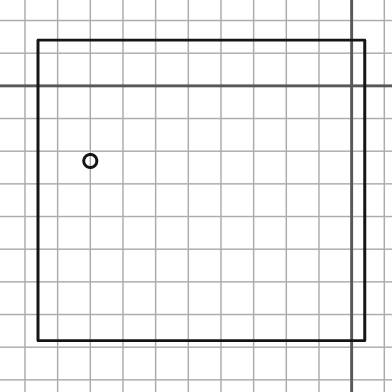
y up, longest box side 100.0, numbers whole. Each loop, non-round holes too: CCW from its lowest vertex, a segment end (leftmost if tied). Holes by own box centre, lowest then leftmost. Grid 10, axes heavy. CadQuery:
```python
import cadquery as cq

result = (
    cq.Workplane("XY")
    .moveTo(-96.0, -78.0)
    .lineTo(4.0, -78.0)
    .lineTo(4.0, 14.0)
    .lineTo(-96.0, 14.0)
    .close()
    .moveTo(-80.0, -23.0)
    .circle(2.0)
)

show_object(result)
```